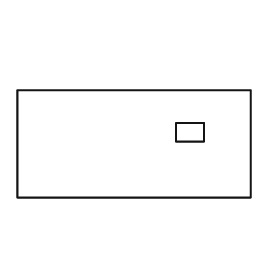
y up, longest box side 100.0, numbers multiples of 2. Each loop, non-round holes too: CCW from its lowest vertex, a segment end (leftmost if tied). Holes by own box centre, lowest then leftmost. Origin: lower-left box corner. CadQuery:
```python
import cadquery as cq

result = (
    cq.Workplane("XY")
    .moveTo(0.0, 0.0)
    .lineTo(100.0, 0.0)
    .lineTo(100.0, 46.0)
    .lineTo(0.0, 46.0)
    .close()
    .moveTo(68.0, 24.0)
    .lineTo(80.0, 24.0)
    .lineTo(80.0, 32.0)
    .lineTo(68.0, 32.0)
    .close()
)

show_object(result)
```